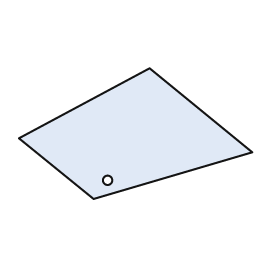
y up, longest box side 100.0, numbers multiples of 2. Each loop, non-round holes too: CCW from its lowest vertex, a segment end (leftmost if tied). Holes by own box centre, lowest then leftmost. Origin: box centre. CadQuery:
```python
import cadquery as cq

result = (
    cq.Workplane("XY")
    .moveTo(-18.0, -28.0)
    .lineTo(50.0, -8.0)
    .lineTo(6.0, 28.0)
    .lineTo(-50.0, -2.0)
    .close()
    .moveTo(-12.0, -20.0)
    .circle(2.0)
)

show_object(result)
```